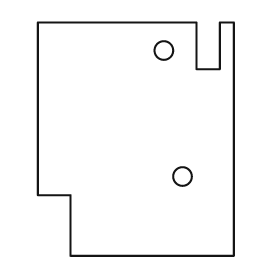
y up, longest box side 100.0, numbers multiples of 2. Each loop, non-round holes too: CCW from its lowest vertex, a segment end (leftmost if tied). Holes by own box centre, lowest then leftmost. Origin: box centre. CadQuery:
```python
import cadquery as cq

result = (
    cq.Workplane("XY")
    .moveTo(-28.0, -50.0)
    .lineTo(42.0, -50.0)
    .lineTo(42.0, 50.0)
    .lineTo(36.0, 50.0)
    .lineTo(36.0, 30.0)
    .lineTo(26.0, 30.0)
    .lineTo(26.0, 50.0)
    .lineTo(-42.0, 50.0)
    .lineTo(-42.0, -24.0)
    .lineTo(-28.0, -24.0)
    .close()
    .moveTo(20.0, -16.0)
    .circle(4.0)
    .moveTo(12.0, 38.0)
    .circle(4.0)
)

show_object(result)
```